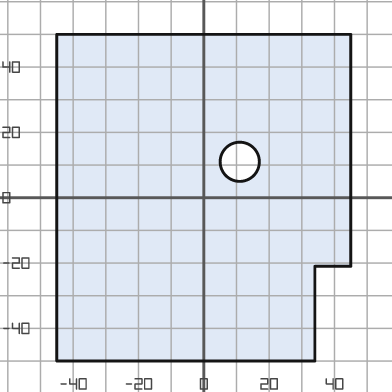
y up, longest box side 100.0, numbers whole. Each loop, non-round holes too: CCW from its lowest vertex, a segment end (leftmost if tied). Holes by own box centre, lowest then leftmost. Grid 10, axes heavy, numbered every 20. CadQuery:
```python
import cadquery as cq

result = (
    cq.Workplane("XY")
    .moveTo(-45.0, -50.0)
    .lineTo(34.0, -50.0)
    .lineTo(34.0, -21.0)
    .lineTo(45.0, -21.0)
    .lineTo(45.0, 50.0)
    .lineTo(-45.0, 50.0)
    .close()
    .moveTo(11.0, 11.0)
    .circle(6.0)
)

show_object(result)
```